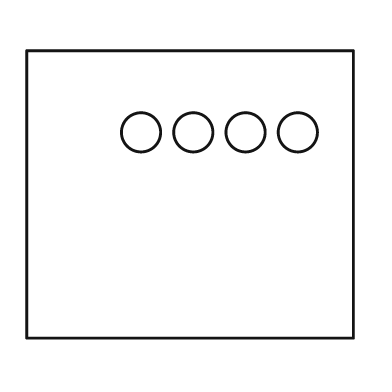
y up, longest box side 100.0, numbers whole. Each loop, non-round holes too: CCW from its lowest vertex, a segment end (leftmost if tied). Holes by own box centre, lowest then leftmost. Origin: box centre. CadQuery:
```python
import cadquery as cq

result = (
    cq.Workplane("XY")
    .moveTo(-50.0, -44.0)
    .lineTo(50.0, -44.0)
    .lineTo(50.0, 44.0)
    .lineTo(-50.0, 44.0)
    .close()
    .moveTo(-15.0, 19.0)
    .circle(6.0)
    .moveTo(1.0, 19.0)
    .circle(6.0)
    .moveTo(17.0, 19.0)
    .circle(6.0)
    .moveTo(33.0, 19.0)
    .circle(6.0)
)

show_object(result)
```